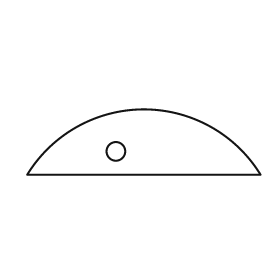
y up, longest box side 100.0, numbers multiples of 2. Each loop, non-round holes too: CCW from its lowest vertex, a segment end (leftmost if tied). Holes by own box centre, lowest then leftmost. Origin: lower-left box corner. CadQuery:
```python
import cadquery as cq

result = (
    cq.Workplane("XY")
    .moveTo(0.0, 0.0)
    .lineTo(100.0, 0.0)
    .threePointArc((50.0, 28.0), (0.0, 0.0))
    .close()
    .moveTo(38.0, 10.0)
    .circle(4.0)
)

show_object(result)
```